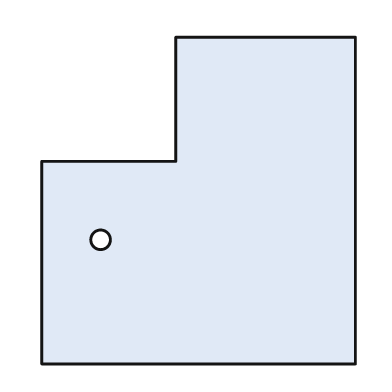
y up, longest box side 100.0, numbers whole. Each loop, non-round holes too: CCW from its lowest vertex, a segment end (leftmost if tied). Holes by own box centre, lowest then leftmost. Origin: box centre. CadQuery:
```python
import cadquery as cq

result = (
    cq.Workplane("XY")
    .moveTo(-48.0, -50.0)
    .lineTo(48.0, -50.0)
    .lineTo(48.0, 50.0)
    .lineTo(-7.0, 50.0)
    .lineTo(-7.0, 12.0)
    .lineTo(-48.0, 12.0)
    .close()
    .moveTo(-30.0, -12.0)
    .circle(3.0)
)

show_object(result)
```